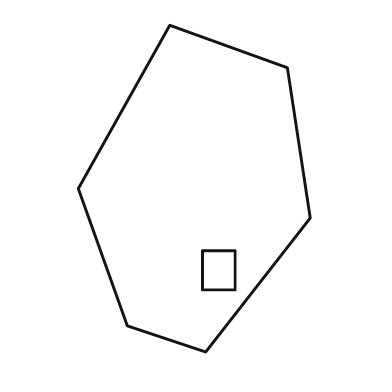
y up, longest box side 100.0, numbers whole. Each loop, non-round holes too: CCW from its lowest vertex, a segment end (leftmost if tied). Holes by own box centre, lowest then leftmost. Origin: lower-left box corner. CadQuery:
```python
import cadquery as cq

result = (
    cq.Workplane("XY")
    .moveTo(39.0, 0.0)
    .lineTo(71.0, 41.0)
    .lineTo(64.0, 87.0)
    .lineTo(28.0, 100.0)
    .lineTo(0.0, 50.0)
    .lineTo(15.0, 8.0)
    .close()
    .moveTo(38.0, 19.0)
    .lineTo(48.0, 19.0)
    .lineTo(48.0, 31.0)
    .lineTo(38.0, 31.0)
    .close()
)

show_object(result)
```